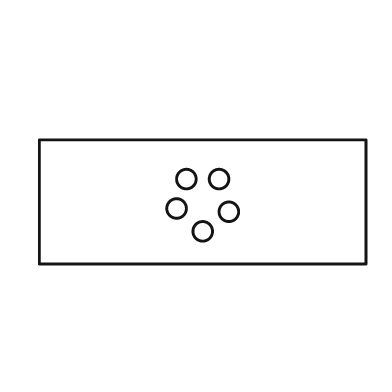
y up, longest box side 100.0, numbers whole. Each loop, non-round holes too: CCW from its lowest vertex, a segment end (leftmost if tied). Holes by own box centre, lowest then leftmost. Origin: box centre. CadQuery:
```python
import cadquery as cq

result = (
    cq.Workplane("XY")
    .moveTo(-50.0, -19.0)
    .lineTo(50.0, -19.0)
    .lineTo(50.0, 19.0)
    .lineTo(-50.0, 19.0)
    .close()
    .moveTo(0.0, -9.0)
    .circle(3.0)
    .moveTo(8.0, -3.0)
    .circle(3.0)
    .moveTo(-8.0, -2.0)
    .circle(3.0)
    .moveTo(-5.0, 7.0)
    .circle(3.0)
    .moveTo(5.0, 7.0)
    .circle(3.0)
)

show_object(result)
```